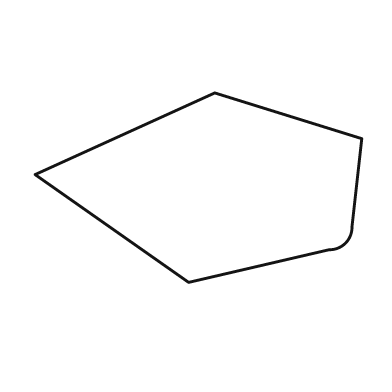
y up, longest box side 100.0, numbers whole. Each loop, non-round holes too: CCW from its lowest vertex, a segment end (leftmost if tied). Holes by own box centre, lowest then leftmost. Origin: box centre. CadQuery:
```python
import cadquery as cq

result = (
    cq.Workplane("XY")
    .moveTo(-3.0, -29.0)
    .lineTo(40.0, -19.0)
    .threePointArc((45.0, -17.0), (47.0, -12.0))
    .lineTo(50.0, 15.0)
    .lineTo(5.0, 29.0)
    .lineTo(-50.0, 4.0)
    .close()
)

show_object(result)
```